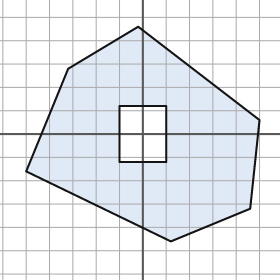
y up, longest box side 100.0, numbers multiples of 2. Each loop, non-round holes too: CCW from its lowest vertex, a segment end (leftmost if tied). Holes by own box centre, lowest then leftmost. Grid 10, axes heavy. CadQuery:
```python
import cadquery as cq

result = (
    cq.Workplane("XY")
    .moveTo(12.0, -46.0)
    .lineTo(46.0, -32.0)
    .lineTo(50.0, 6.0)
    .lineTo(-2.0, 46.0)
    .lineTo(-32.0, 28.0)
    .lineTo(-50.0, -16.0)
    .close()
    .moveTo(-10.0, -12.0)
    .lineTo(10.0, -12.0)
    .lineTo(10.0, 12.0)
    .lineTo(-10.0, 12.0)
    .close()
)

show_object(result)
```